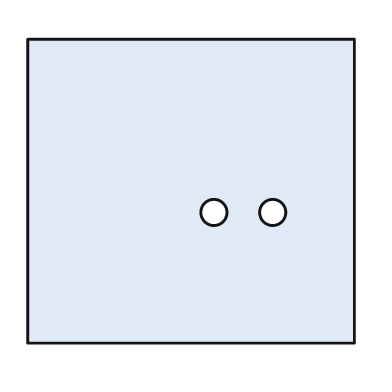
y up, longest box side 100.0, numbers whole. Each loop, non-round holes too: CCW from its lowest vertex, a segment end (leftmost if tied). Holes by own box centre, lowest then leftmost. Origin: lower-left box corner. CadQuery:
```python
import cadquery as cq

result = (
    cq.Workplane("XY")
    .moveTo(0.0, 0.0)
    .lineTo(100.0, 0.0)
    .lineTo(100.0, 93.0)
    .lineTo(0.0, 93.0)
    .close()
    .moveTo(57.0, 40.0)
    .circle(4.0)
    .moveTo(75.0, 40.0)
    .circle(4.0)
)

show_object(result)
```